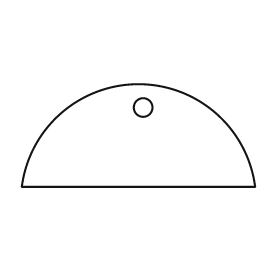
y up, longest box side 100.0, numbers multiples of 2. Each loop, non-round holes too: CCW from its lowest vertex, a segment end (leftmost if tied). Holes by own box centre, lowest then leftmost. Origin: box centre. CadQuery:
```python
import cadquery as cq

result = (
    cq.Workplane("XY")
    .moveTo(-50.0, -22.0)
    .lineTo(50.0, -22.0)
    .threePointArc((0.0, 22.0), (-50.0, -22.0))
    .close()
    .moveTo(2.0, 12.0)
    .circle(4.0)
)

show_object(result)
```